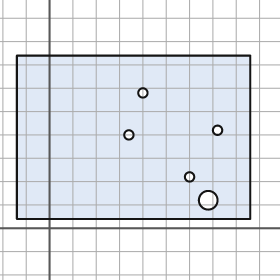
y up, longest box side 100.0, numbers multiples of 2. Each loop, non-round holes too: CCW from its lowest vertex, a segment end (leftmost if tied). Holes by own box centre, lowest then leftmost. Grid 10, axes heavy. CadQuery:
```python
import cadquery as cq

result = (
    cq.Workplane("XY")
    .moveTo(-14.0, 4.0)
    .lineTo(86.0, 4.0)
    .lineTo(86.0, 74.0)
    .lineTo(-14.0, 74.0)
    .close()
    .moveTo(68.0, 12.0)
    .circle(4.0)
    .moveTo(60.0, 22.0)
    .circle(2.0)
    .moveTo(34.0, 40.0)
    .circle(2.0)
    .moveTo(72.0, 42.0)
    .circle(2.0)
    .moveTo(40.0, 58.0)
    .circle(2.0)
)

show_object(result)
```